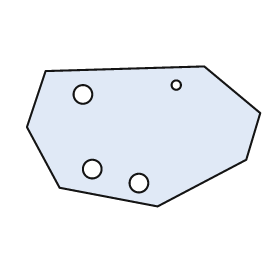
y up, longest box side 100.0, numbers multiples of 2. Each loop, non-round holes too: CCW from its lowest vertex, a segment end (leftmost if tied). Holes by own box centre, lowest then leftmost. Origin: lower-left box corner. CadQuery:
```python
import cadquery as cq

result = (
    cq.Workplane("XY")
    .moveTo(56.0, 0.0)
    .lineTo(94.0, 20.0)
    .lineTo(100.0, 40.0)
    .lineTo(76.0, 60.0)
    .lineTo(8.0, 58.0)
    .lineTo(0.0, 34.0)
    .lineTo(14.0, 8.0)
    .close()
    .moveTo(48.0, 10.0)
    .circle(4.0)
    .moveTo(28.0, 16.0)
    .circle(4.0)
    .moveTo(24.0, 48.0)
    .circle(4.0)
    .moveTo(64.0, 52.0)
    .circle(2.0)
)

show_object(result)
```